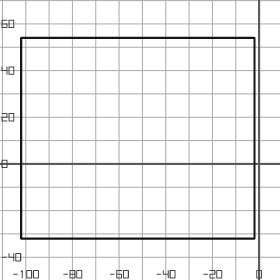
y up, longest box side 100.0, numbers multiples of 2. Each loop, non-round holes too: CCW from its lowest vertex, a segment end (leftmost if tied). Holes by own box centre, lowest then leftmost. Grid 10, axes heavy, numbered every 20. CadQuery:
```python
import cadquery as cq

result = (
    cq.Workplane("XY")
    .moveTo(-102.0, -32.0)
    .lineTo(-2.0, -32.0)
    .lineTo(-2.0, 54.0)
    .lineTo(-102.0, 54.0)
    .close()
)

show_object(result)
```